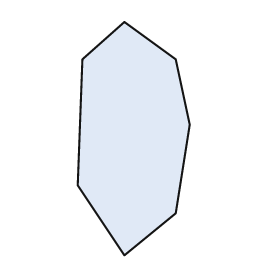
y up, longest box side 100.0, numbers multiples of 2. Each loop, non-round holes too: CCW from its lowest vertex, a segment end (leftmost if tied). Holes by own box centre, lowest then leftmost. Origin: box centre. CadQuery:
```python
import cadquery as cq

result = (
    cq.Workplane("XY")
    .moveTo(-4.0, -50.0)
    .lineTo(18.0, -32.0)
    .lineTo(24.0, 6.0)
    .lineTo(18.0, 34.0)
    .lineTo(-4.0, 50.0)
    .lineTo(-22.0, 34.0)
    .lineTo(-24.0, -20.0)
    .close()
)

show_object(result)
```